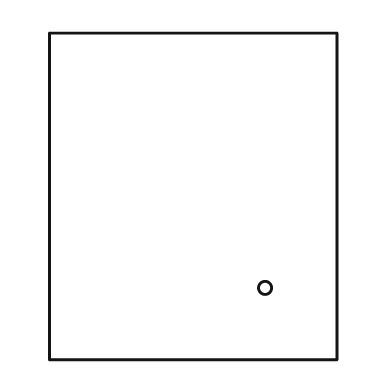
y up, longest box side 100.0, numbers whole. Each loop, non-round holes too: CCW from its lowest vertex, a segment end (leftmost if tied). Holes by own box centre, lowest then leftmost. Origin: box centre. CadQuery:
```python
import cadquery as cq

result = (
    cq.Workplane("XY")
    .moveTo(-44.0, -50.0)
    .lineTo(44.0, -50.0)
    .lineTo(44.0, 50.0)
    .lineTo(-44.0, 50.0)
    .close()
    .moveTo(22.0, -28.0)
    .circle(2.0)
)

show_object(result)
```